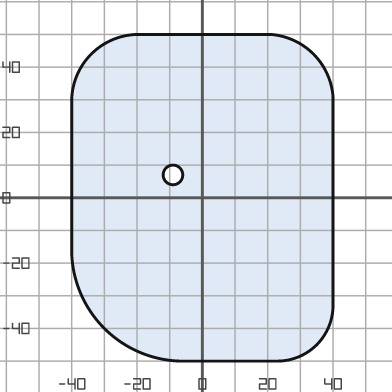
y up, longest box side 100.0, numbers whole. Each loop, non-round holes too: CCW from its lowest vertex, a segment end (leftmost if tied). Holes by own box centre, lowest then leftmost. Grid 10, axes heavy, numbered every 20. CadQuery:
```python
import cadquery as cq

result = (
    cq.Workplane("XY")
    .moveTo(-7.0, -50.0)
    .lineTo(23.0, -50.0)
    .threePointArc((35.0, -45.0), (40.0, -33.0))
    .lineTo(40.0, 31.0)
    .threePointArc((34.0, 44.0), (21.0, 50.0))
    .lineTo(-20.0, 50.0)
    .threePointArc((-34.0, 44.0), (-40.0, 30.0))
    .lineTo(-40.0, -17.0)
    .threePointArc((-30.0, -40.0), (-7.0, -50.0))
    .close()
    .moveTo(-9.0, 7.0)
    .circle(3.0)
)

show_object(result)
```